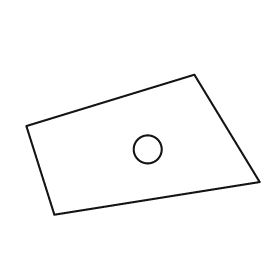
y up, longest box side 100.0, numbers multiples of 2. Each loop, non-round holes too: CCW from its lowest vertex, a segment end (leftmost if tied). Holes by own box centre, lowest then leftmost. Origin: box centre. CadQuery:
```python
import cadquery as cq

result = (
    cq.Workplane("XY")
    .moveTo(-38.0, -30.0)
    .lineTo(50.0, -16.0)
    .lineTo(22.0, 30.0)
    .lineTo(-50.0, 8.0)
    .close()
    .moveTo(2.0, -2.0)
    .circle(6.0)
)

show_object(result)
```